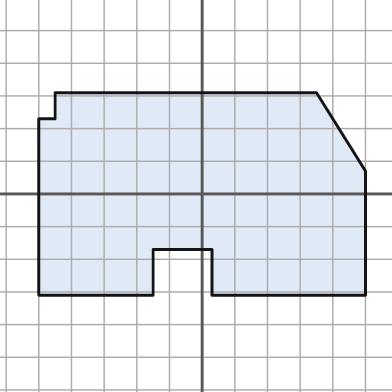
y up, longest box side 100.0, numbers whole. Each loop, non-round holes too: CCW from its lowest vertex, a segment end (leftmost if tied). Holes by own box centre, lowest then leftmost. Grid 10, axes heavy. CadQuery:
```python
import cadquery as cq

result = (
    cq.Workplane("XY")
    .moveTo(-50.0, -31.0)
    .lineTo(-15.0, -31.0)
    .lineTo(-15.0, -17.0)
    .lineTo(3.0, -17.0)
    .lineTo(3.0, -31.0)
    .lineTo(50.0, -31.0)
    .lineTo(50.0, 7.0)
    .lineTo(35.0, 31.0)
    .lineTo(-45.0, 31.0)
    .lineTo(-45.0, 23.0)
    .lineTo(-50.0, 23.0)
    .close()
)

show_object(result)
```